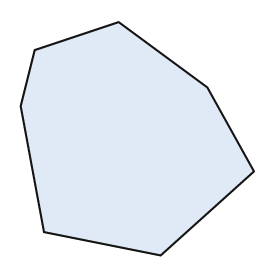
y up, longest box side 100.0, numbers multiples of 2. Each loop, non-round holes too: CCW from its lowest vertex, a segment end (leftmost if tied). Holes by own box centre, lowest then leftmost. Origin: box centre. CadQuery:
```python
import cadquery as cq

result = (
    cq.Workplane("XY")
    .moveTo(10.0, -50.0)
    .lineTo(50.0, -14.0)
    .lineTo(30.0, 22.0)
    .lineTo(-8.0, 50.0)
    .lineTo(-44.0, 38.0)
    .lineTo(-50.0, 14.0)
    .lineTo(-40.0, -40.0)
    .close()
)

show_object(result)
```